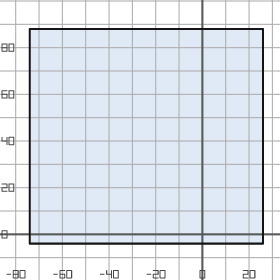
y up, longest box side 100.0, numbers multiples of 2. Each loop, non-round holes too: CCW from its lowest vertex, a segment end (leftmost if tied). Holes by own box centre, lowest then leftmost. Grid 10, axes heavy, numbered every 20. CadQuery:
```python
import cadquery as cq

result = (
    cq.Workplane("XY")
    .moveTo(-74.0, -4.0)
    .lineTo(26.0, -4.0)
    .lineTo(26.0, 88.0)
    .lineTo(-74.0, 88.0)
    .close()
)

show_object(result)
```